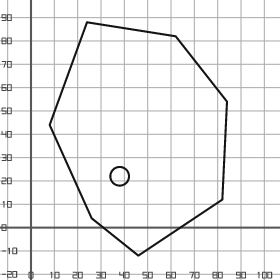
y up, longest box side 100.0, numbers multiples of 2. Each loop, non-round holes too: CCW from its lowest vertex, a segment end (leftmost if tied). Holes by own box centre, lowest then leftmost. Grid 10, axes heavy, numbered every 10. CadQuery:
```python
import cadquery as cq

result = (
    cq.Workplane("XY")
    .moveTo(46.0, -12.0)
    .lineTo(82.0, 12.0)
    .lineTo(84.0, 54.0)
    .lineTo(62.0, 82.0)
    .lineTo(24.0, 88.0)
    .lineTo(8.0, 44.0)
    .lineTo(26.0, 4.0)
    .close()
    .moveTo(38.0, 22.0)
    .circle(4.0)
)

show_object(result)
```